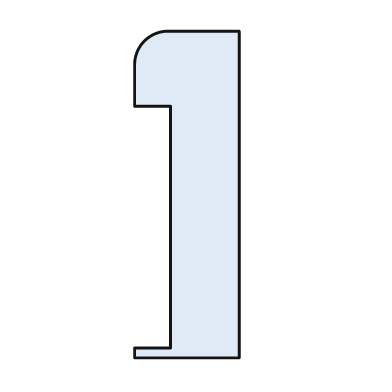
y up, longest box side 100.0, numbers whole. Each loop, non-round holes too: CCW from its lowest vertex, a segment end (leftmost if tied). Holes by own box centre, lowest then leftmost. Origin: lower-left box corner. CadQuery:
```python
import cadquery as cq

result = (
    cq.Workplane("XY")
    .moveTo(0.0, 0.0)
    .lineTo(32.0, 0.0)
    .lineTo(32.0, 100.0)
    .lineTo(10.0, 100.0)
    .threePointArc((3.0, 97.0), (0.0, 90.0))
    .lineTo(0.0, 77.0)
    .lineTo(11.0, 77.0)
    .lineTo(11.0, 3.0)
    .lineTo(0.0, 3.0)
    .close()
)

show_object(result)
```